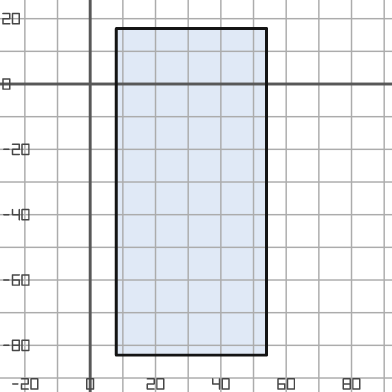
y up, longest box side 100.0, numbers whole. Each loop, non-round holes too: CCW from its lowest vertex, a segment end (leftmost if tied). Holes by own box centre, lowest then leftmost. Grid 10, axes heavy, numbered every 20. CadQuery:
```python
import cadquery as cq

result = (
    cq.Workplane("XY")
    .moveTo(8.0, -83.0)
    .lineTo(54.0, -83.0)
    .lineTo(54.0, 17.0)
    .lineTo(8.0, 17.0)
    .close()
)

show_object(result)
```